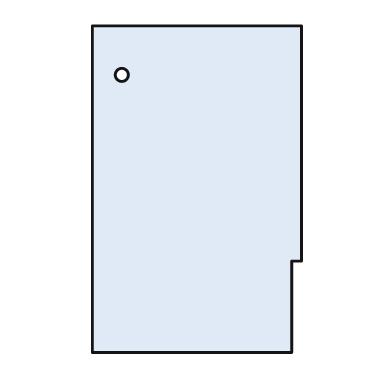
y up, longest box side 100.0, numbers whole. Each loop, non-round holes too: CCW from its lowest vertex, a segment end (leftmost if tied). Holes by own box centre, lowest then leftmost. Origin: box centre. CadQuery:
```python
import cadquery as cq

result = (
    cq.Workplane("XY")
    .moveTo(-32.0, -50.0)
    .lineTo(29.0, -50.0)
    .lineTo(29.0, -22.0)
    .lineTo(32.0, -22.0)
    .lineTo(32.0, 50.0)
    .lineTo(-32.0, 50.0)
    .close()
    .moveTo(-23.0, 35.0)
    .circle(2.0)
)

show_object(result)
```